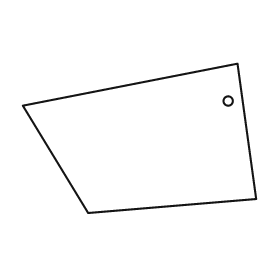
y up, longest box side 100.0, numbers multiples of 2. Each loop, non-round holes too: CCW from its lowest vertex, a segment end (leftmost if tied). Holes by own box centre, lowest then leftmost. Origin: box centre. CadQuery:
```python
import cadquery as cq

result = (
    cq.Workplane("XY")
    .moveTo(-22.0, -32.0)
    .lineTo(50.0, -26.0)
    .lineTo(42.0, 32.0)
    .lineTo(-50.0, 14.0)
    .close()
    .moveTo(38.0, 16.0)
    .circle(2.0)
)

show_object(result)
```